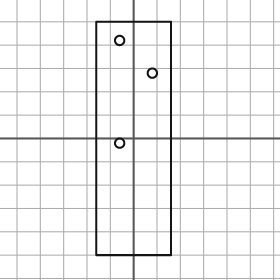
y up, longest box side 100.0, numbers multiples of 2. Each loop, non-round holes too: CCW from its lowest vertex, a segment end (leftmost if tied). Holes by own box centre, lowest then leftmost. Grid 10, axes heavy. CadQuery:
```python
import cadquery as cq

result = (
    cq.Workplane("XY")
    .moveTo(-16.0, -50.0)
    .lineTo(16.0, -50.0)
    .lineTo(16.0, 50.0)
    .lineTo(-16.0, 50.0)
    .close()
    .moveTo(-6.0, -2.0)
    .circle(2.0)
    .moveTo(8.0, 28.0)
    .circle(2.0)
    .moveTo(-6.0, 42.0)
    .circle(2.0)
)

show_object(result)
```